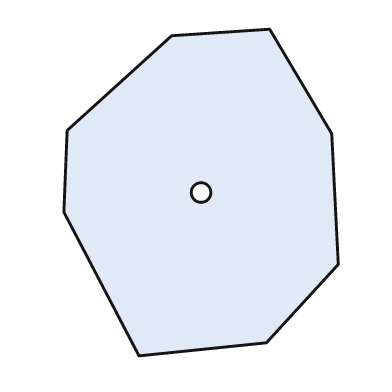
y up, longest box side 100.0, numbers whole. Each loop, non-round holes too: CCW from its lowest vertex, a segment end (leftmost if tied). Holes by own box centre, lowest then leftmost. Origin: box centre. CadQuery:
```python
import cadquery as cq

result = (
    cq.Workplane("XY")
    .moveTo(-19.0, -50.0)
    .lineTo(20.0, -46.0)
    .lineTo(42.0, -22.0)
    .lineTo(40.0, 18.0)
    .lineTo(21.0, 50.0)
    .lineTo(-9.0, 48.0)
    .lineTo(-41.0, 19.0)
    .lineTo(-42.0, -6.0)
    .close()
    .moveTo(0.0, 0.0)
    .circle(3.0)
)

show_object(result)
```